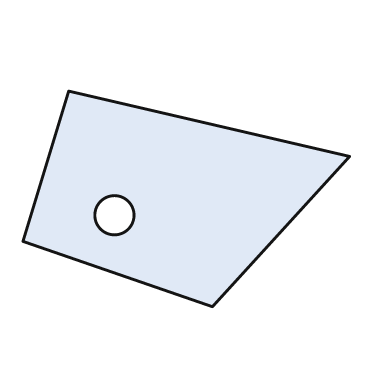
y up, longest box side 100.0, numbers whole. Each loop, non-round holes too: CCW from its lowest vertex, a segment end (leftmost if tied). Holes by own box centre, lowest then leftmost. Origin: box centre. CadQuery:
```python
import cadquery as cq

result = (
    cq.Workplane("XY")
    .moveTo(8.0, -33.0)
    .lineTo(50.0, 13.0)
    .lineTo(-36.0, 33.0)
    .lineTo(-50.0, -13.0)
    .close()
    .moveTo(-22.0, -5.0)
    .circle(6.0)
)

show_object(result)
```